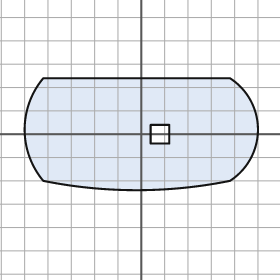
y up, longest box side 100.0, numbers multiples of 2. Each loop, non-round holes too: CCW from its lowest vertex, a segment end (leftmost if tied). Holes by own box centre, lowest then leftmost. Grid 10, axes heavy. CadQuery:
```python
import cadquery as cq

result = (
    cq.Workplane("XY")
    .moveTo(-42.0, -20.0)
    .threePointArc((-2.0, -24.0), (38.0, -20.0))
    .threePointArc((50.0, 2.0), (38.0, 24.0))
    .lineTo(-42.0, 24.0)
    .threePointArc((-50.0, 2.0), (-42.0, -20.0))
    .close()
    .moveTo(4.0, -4.0)
    .lineTo(12.0, -4.0)
    .lineTo(12.0, 4.0)
    .lineTo(4.0, 4.0)
    .close()
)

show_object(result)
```